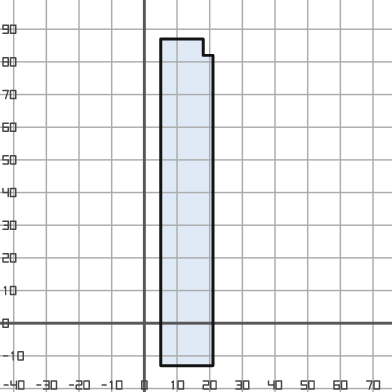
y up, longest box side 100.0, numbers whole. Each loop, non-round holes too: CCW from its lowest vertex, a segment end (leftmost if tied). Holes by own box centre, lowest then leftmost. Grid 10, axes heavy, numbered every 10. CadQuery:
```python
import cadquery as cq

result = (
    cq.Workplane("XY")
    .moveTo(5.0, -13.0)
    .lineTo(21.0, -13.0)
    .lineTo(21.0, 82.0)
    .lineTo(18.0, 82.0)
    .lineTo(18.0, 87.0)
    .lineTo(5.0, 87.0)
    .close()
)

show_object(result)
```